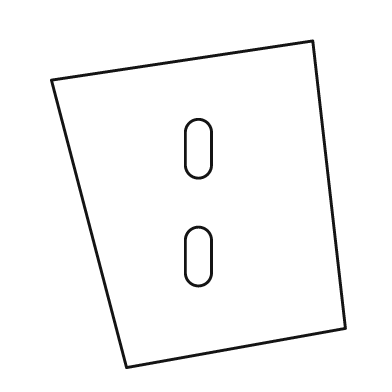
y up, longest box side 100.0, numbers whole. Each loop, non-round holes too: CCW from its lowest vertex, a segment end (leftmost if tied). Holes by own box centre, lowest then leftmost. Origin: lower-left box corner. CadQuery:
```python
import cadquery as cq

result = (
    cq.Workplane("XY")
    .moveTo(23.0, 0.0)
    .lineTo(90.0, 12.0)
    .lineTo(80.0, 100.0)
    .lineTo(0.0, 88.0)
    .close()
    .moveTo(41.0, 29.0)
    .threePointArc((45.0, 25.0), (49.0, 29.0))
    .lineTo(49.0, 39.0)
    .threePointArc((45.0, 43.0), (41.0, 39.0))
    .close()
    .moveTo(41.0, 62.0)
    .threePointArc((45.0, 58.0), (49.0, 62.0))
    .lineTo(49.0, 72.0)
    .threePointArc((45.0, 76.0), (41.0, 72.0))
    .close()
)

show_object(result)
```